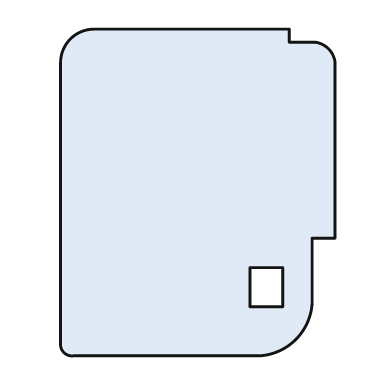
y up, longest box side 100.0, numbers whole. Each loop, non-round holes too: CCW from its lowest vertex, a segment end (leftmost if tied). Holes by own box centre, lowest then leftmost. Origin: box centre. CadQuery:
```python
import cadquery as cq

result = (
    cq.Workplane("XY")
    .moveTo(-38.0, -50.0)
    .lineTo(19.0, -50.0)
    .threePointArc((30.0, -45.0), (35.0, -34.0))
    .lineTo(35.0, -14.0)
    .lineTo(42.0, -14.0)
    .lineTo(42.0, 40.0)
    .threePointArc((40.0, 44.0), (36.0, 46.0))
    .lineTo(28.0, 46.0)
    .lineTo(28.0, 50.0)
    .lineTo(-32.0, 50.0)
    .threePointArc((-39.0, 47.0), (-42.0, 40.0))
    .lineTo(-42.0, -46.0)
    .threePointArc((-41.0, -49.0), (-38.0, -50.0))
    .close()
    .moveTo(16.0, -35.0)
    .lineTo(26.0, -35.0)
    .lineTo(26.0, -23.0)
    .lineTo(16.0, -23.0)
    .close()
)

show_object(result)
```